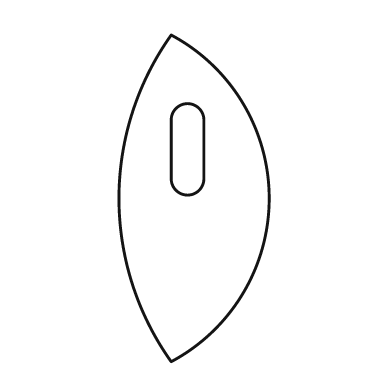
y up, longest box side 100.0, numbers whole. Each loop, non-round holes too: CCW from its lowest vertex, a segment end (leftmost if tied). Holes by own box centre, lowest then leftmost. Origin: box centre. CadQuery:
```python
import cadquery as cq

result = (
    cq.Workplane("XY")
    .moveTo(-7.0, -50.0)
    .threePointArc((23.0, 0.0), (-7.0, 50.0))
    .threePointArc((-23.0, 0.0), (-7.0, -50.0))
    .close()
    .moveTo(-7.0, 6.0)
    .threePointArc((-2.0, 1.0), (3.0, 6.0))
    .lineTo(3.0, 24.0)
    .threePointArc((-2.0, 29.0), (-7.0, 24.0))
    .close()
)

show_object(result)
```